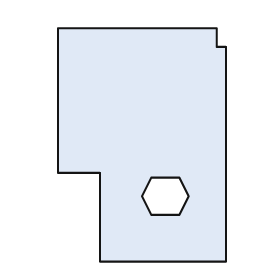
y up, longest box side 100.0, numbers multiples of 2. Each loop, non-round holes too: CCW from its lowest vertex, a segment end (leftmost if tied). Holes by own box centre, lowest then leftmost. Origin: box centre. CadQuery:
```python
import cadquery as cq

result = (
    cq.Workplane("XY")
    .moveTo(-18.0, -50.0)
    .lineTo(36.0, -50.0)
    .lineTo(36.0, 42.0)
    .lineTo(32.0, 42.0)
    .lineTo(32.0, 50.0)
    .lineTo(-36.0, 50.0)
    .lineTo(-36.0, -12.0)
    .lineTo(-18.0, -12.0)
    .close()
    .moveTo(4.0, -30.0)
    .lineTo(16.0, -30.0)
    .lineTo(20.0, -22.0)
    .lineTo(16.0, -14.0)
    .lineTo(4.0, -14.0)
    .lineTo(0.0, -22.0)
    .close()
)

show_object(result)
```